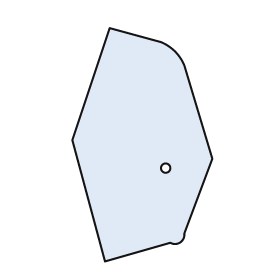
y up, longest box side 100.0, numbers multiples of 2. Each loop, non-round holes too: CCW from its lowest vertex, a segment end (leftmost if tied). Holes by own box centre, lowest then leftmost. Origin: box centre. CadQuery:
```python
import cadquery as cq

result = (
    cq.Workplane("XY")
    .moveTo(-16.0, -50.0)
    .lineTo(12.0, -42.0)
    .threePointArc((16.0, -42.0), (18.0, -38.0))
    .lineTo(30.0, -6.0)
    .lineTo(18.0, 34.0)
    .threePointArc((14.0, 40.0), (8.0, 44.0))
    .lineTo(-14.0, 50.0)
    .lineTo(-30.0, 2.0)
    .close()
    .moveTo(10.0, -10.0)
    .circle(2.0)
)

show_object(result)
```